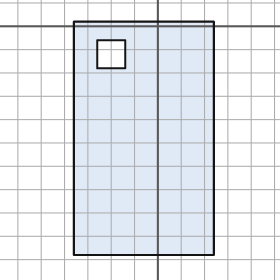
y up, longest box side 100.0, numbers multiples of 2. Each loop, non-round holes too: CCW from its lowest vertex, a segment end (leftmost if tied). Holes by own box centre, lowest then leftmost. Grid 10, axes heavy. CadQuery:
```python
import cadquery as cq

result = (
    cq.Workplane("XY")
    .moveTo(-36.0, -98.0)
    .lineTo(24.0, -98.0)
    .lineTo(24.0, 2.0)
    .lineTo(-36.0, 2.0)
    .close()
    .moveTo(-26.0, -18.0)
    .lineTo(-14.0, -18.0)
    .lineTo(-14.0, -6.0)
    .lineTo(-26.0, -6.0)
    .close()
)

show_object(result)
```